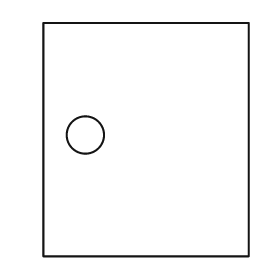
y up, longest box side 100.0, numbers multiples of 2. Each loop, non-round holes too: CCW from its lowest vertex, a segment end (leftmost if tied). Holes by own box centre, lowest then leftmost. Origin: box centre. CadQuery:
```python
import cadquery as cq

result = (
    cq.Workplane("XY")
    .moveTo(-44.0, -50.0)
    .lineTo(44.0, -50.0)
    .lineTo(44.0, 50.0)
    .lineTo(-44.0, 50.0)
    .close()
    .moveTo(-26.0, 2.0)
    .circle(8.0)
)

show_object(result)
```